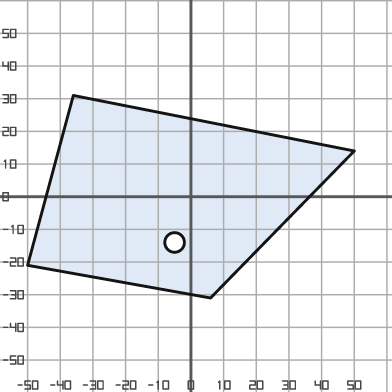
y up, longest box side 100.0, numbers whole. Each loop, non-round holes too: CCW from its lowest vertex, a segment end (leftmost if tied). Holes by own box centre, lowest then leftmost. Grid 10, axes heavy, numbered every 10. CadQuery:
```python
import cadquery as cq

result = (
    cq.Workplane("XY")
    .moveTo(6.0, -31.0)
    .lineTo(50.0, 14.0)
    .lineTo(-36.0, 31.0)
    .lineTo(-50.0, -21.0)
    .close()
    .moveTo(-5.0, -14.0)
    .circle(3.0)
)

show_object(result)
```